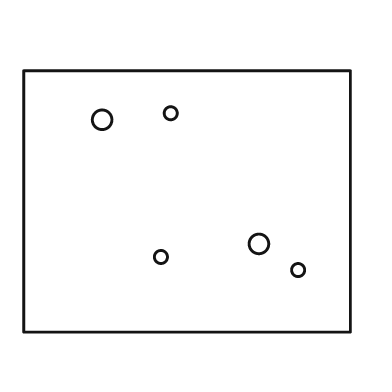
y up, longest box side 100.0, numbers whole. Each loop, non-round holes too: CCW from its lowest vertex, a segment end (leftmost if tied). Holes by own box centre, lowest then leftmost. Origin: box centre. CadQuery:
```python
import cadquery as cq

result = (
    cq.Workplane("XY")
    .moveTo(-50.0, -40.0)
    .lineTo(50.0, -40.0)
    .lineTo(50.0, 40.0)
    .lineTo(-50.0, 40.0)
    .close()
    .moveTo(34.0, -21.0)
    .circle(2.0)
    .moveTo(-8.0, -17.0)
    .circle(2.0)
    .moveTo(22.0, -13.0)
    .circle(3.0)
    .moveTo(-26.0, 25.0)
    .circle(3.0)
    .moveTo(-5.0, 27.0)
    .circle(2.0)
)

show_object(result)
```